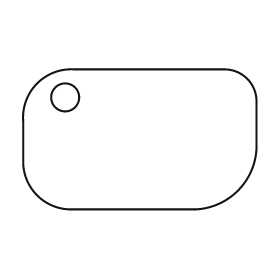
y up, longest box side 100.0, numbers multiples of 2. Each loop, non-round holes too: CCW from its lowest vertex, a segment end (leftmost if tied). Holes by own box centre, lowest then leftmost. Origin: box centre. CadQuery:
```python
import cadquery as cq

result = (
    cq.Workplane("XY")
    .moveTo(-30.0, -30.0)
    .lineTo(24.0, -30.0)
    .threePointArc((42.0, -22.0), (50.0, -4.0))
    .lineTo(50.0, 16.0)
    .threePointArc((46.0, 26.0), (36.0, 30.0))
    .lineTo(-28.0, 30.0)
    .threePointArc((-44.0, 24.0), (-50.0, 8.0))
    .lineTo(-50.0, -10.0)
    .threePointArc((-44.0, -24.0), (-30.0, -30.0))
    .close()
    .moveTo(-32.0, 18.0)
    .circle(6.0)
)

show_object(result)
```